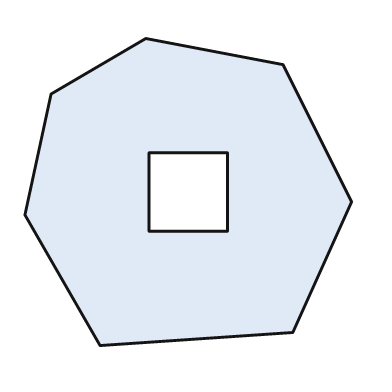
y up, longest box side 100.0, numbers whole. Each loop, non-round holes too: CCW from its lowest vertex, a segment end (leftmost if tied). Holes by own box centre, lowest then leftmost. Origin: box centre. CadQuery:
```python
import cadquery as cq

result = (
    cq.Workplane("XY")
    .moveTo(-27.0, -47.0)
    .lineTo(32.0, -43.0)
    .lineTo(50.0, -3.0)
    .lineTo(29.0, 39.0)
    .lineTo(-13.0, 47.0)
    .lineTo(-42.0, 30.0)
    .lineTo(-50.0, -7.0)
    .close()
    .moveTo(-12.0, -12.0)
    .lineTo(12.0, -12.0)
    .lineTo(12.0, 12.0)
    .lineTo(-12.0, 12.0)
    .close()
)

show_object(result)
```